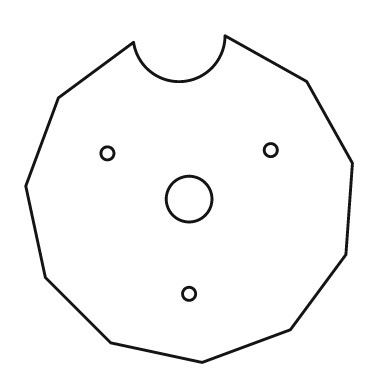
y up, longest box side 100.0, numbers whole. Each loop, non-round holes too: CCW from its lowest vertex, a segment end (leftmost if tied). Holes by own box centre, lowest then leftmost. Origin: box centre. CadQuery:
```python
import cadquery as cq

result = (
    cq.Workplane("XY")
    .moveTo(4.0, -50.0)
    .lineTo(31.0, -40.0)
    .lineTo(48.0, -17.0)
    .lineTo(50.0, 11.0)
    .lineTo(36.0, 36.0)
    .lineTo(11.0, 50.0)
    .threePointArc((-2.0, 36.0), (-17.0, 48.0))
    .lineTo(-40.0, 31.0)
    .lineTo(-50.0, 4.0)
    .lineTo(-44.0, -24.0)
    .lineTo(-24.0, -44.0)
    .close()
    .moveTo(0.0, -29.0)
    .circle(2.0)
    .moveTo(0.0, 0.0)
    .circle(7.0)
    .moveTo(-25.0, 14.0)
    .circle(2.0)
    .moveTo(25.0, 15.0)
    .circle(2.0)
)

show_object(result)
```